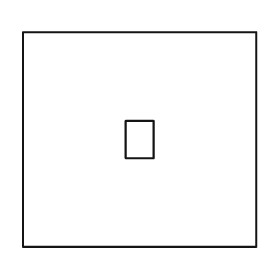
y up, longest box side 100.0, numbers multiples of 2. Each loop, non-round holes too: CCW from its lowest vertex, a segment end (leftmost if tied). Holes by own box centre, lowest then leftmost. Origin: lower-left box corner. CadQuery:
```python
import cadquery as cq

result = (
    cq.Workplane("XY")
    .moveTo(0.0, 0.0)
    .lineTo(100.0, 0.0)
    .lineTo(100.0, 92.0)
    .lineTo(0.0, 92.0)
    .close()
    .moveTo(44.0, 38.0)
    .lineTo(56.0, 38.0)
    .lineTo(56.0, 54.0)
    .lineTo(44.0, 54.0)
    .close()
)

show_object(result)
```